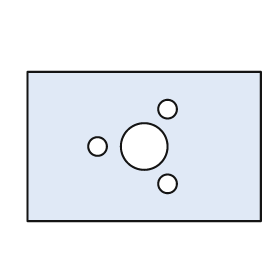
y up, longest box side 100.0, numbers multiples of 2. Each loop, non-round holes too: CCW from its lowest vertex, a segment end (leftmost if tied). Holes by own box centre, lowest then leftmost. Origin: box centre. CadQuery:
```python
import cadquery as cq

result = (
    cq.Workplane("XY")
    .moveTo(-50.0, -32.0)
    .lineTo(50.0, -32.0)
    .lineTo(50.0, 32.0)
    .lineTo(-50.0, 32.0)
    .close()
    .moveTo(10.0, -16.0)
    .circle(4.0)
    .moveTo(-20.0, 0.0)
    .circle(4.0)
    .moveTo(0.0, 0.0)
    .circle(10.0)
    .moveTo(10.0, 16.0)
    .circle(4.0)
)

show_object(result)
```